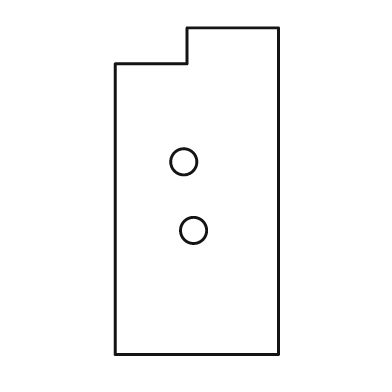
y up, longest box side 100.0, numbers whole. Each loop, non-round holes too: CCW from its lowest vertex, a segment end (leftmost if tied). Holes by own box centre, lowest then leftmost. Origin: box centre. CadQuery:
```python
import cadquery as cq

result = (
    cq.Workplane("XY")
    .moveTo(-25.0, -50.0)
    .lineTo(25.0, -50.0)
    .lineTo(25.0, 50.0)
    .lineTo(-3.0, 50.0)
    .lineTo(-3.0, 39.0)
    .lineTo(-25.0, 39.0)
    .close()
    .moveTo(-1.0, -12.0)
    .circle(4.0)
    .moveTo(-4.0, 9.0)
    .circle(4.0)
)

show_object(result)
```